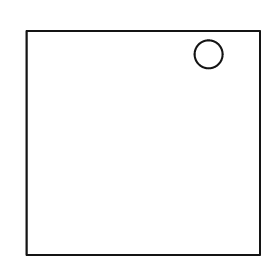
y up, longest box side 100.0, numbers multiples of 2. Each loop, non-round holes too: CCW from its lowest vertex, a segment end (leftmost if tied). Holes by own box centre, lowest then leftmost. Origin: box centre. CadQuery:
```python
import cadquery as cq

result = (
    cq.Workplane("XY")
    .moveTo(-50.0, -48.0)
    .lineTo(50.0, -48.0)
    .lineTo(50.0, 48.0)
    .lineTo(-50.0, 48.0)
    .close()
    .moveTo(28.0, 38.0)
    .circle(6.0)
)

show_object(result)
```